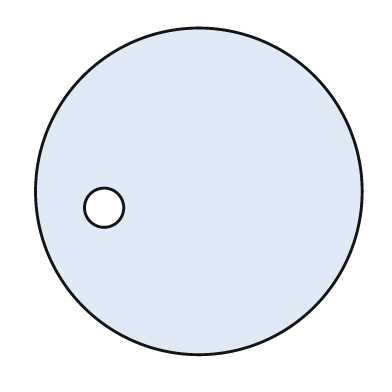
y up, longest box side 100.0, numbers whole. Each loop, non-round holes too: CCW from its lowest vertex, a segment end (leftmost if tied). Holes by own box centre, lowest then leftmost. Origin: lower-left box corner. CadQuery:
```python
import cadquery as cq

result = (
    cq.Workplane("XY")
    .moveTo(50.0, 50.0)
    .circle(50.0)
    .moveTo(21.0, 45.0)
    .circle(6.0)
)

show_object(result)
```